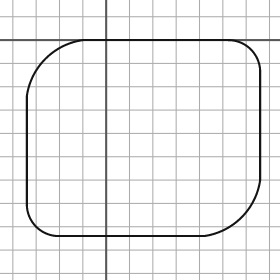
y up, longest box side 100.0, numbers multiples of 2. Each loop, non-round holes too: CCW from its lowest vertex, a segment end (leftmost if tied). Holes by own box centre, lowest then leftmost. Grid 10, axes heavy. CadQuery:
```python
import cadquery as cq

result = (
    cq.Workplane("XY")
    .moveTo(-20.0, -84.0)
    .lineTo(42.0, -84.0)
    .threePointArc((58.0, -76.0), (66.0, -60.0))
    .lineTo(66.0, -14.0)
    .threePointArc((62.0, -4.0), (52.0, 0.0))
    .lineTo(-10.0, 0.0)
    .threePointArc((-26.0, -8.0), (-34.0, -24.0))
    .lineTo(-34.0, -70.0)
    .threePointArc((-30.0, -80.0), (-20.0, -84.0))
    .close()
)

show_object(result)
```